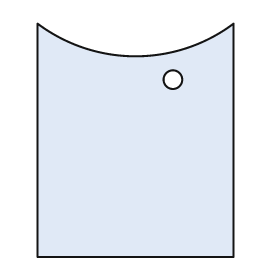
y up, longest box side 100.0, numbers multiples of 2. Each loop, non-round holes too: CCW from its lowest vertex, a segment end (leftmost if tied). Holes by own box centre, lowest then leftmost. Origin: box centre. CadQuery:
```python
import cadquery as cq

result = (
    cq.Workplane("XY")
    .moveTo(-42.0, -50.0)
    .lineTo(42.0, -50.0)
    .lineTo(42.0, 50.0)
    .threePointArc((0.0, 36.0), (-42.0, 50.0))
    .close()
    .moveTo(16.0, 26.0)
    .circle(4.0)
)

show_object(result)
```